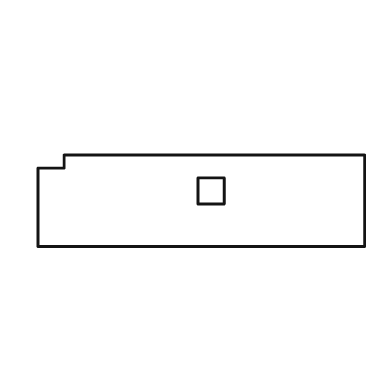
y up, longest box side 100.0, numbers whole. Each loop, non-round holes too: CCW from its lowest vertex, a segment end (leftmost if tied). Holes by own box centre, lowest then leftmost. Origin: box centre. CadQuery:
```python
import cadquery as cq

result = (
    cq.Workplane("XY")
    .moveTo(-50.0, -14.0)
    .lineTo(50.0, -14.0)
    .lineTo(50.0, 14.0)
    .lineTo(-42.0, 14.0)
    .lineTo(-42.0, 10.0)
    .lineTo(-50.0, 10.0)
    .close()
    .moveTo(-1.0, -1.0)
    .lineTo(7.0, -1.0)
    .lineTo(7.0, 7.0)
    .lineTo(-1.0, 7.0)
    .close()
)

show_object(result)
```